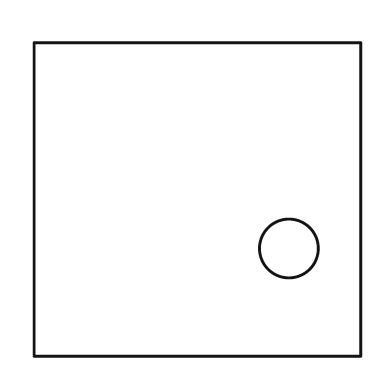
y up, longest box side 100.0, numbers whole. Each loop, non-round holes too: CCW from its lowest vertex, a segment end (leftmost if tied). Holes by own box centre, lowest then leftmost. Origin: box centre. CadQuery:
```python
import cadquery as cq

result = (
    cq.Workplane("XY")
    .moveTo(-50.0, -48.0)
    .lineTo(50.0, -48.0)
    .lineTo(50.0, 48.0)
    .lineTo(-50.0, 48.0)
    .close()
    .moveTo(28.0, -15.0)
    .circle(9.0)
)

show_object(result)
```